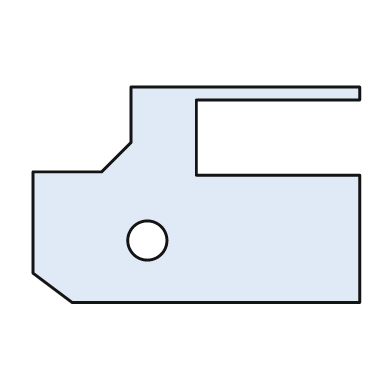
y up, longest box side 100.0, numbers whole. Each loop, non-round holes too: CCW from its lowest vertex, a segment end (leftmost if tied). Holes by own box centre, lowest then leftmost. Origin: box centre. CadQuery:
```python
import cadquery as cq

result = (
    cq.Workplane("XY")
    .moveTo(-38.0, -33.0)
    .lineTo(50.0, -33.0)
    .lineTo(50.0, 6.0)
    .lineTo(0.0, 6.0)
    .lineTo(0.0, 29.0)
    .lineTo(50.0, 29.0)
    .lineTo(50.0, 33.0)
    .lineTo(-20.0, 33.0)
    .lineTo(-20.0, 16.0)
    .lineTo(-29.0, 7.0)
    .lineTo(-50.0, 7.0)
    .lineTo(-50.0, -24.0)
    .close()
    .moveTo(-15.0, -14.0)
    .circle(6.0)
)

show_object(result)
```